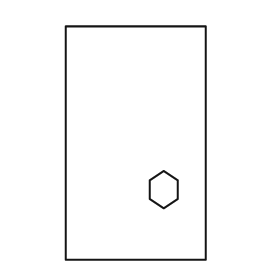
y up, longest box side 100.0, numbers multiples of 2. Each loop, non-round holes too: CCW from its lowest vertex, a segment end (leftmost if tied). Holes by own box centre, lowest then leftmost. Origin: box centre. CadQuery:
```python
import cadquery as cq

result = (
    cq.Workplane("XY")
    .moveTo(-30.0, -50.0)
    .lineTo(30.0, -50.0)
    .lineTo(30.0, 50.0)
    .lineTo(-30.0, 50.0)
    .close()
    .moveTo(12.0, -28.0)
    .lineTo(18.0, -24.0)
    .lineTo(18.0, -16.0)
    .lineTo(12.0, -12.0)
    .lineTo(6.0, -16.0)
    .lineTo(6.0, -24.0)
    .close()
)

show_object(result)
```